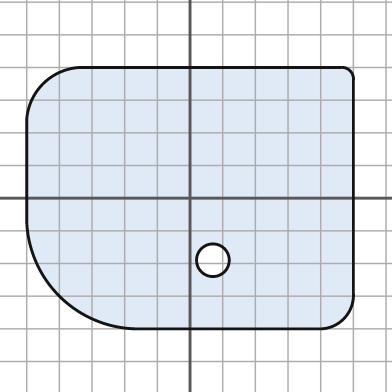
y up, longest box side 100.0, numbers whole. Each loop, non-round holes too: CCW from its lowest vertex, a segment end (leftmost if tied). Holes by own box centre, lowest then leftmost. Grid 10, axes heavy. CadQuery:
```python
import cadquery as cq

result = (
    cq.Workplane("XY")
    .moveTo(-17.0, -40.0)
    .lineTo(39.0, -40.0)
    .threePointArc((47.0, -37.0), (50.0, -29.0))
    .lineTo(50.0, 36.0)
    .threePointArc((49.0, 39.0), (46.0, 40.0))
    .lineTo(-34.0, 40.0)
    .threePointArc((-45.0, 35.0), (-50.0, 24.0))
    .lineTo(-50.0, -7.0)
    .threePointArc((-40.0, -30.0), (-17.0, -40.0))
    .close()
    .moveTo(7.0, -19.0)
    .circle(5.0)
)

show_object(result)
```